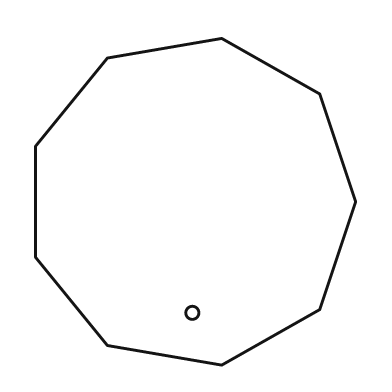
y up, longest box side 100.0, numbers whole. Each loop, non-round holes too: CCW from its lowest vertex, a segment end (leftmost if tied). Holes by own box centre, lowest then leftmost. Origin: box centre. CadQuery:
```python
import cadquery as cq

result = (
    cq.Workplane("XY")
    .moveTo(8.0, -50.0)
    .lineTo(38.0, -33.0)
    .lineTo(49.0, 0.0)
    .lineTo(38.0, 33.0)
    .lineTo(8.0, 50.0)
    .lineTo(-27.0, 44.0)
    .lineTo(-49.0, 17.0)
    .lineTo(-49.0, -17.0)
    .lineTo(-27.0, -44.0)
    .close()
    .moveTo(-1.0, -34.0)
    .circle(2.0)
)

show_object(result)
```